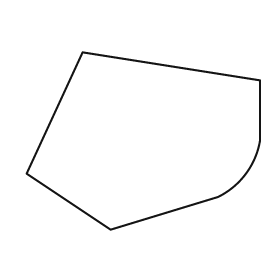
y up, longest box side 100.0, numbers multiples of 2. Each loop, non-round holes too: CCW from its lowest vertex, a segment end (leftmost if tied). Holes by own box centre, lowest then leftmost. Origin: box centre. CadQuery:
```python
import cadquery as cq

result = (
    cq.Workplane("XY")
    .moveTo(-14.0, -38.0)
    .lineTo(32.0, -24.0)
    .threePointArc((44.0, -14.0), (50.0, 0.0))
    .lineTo(50.0, 26.0)
    .lineTo(-26.0, 38.0)
    .lineTo(-50.0, -14.0)
    .close()
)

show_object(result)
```